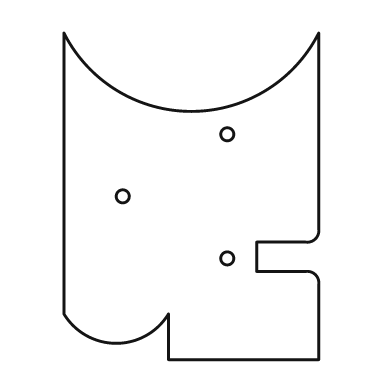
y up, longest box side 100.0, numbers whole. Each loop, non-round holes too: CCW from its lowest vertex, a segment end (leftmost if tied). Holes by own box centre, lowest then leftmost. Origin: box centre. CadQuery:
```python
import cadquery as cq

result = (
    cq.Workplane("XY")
    .moveTo(-7.0, -50.0)
    .lineTo(39.0, -50.0)
    .lineTo(39.0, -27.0)
    .threePointArc((38.0, -24.0), (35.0, -23.0))
    .lineTo(20.0, -23.0)
    .lineTo(20.0, -14.0)
    .lineTo(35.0, -14.0)
    .threePointArc((38.0, -13.0), (39.0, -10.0))
    .lineTo(39.0, 50.0)
    .threePointArc((0.0, 26.0), (-39.0, 50.0))
    .lineTo(-39.0, -36.0)
    .threePointArc((-23.0, -45.0), (-7.0, -36.0))
    .close()
    .moveTo(11.0, -19.0)
    .circle(2.0)
    .moveTo(-21.0, 0.0)
    .circle(2.0)
    .moveTo(11.0, 19.0)
    .circle(2.0)
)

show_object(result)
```